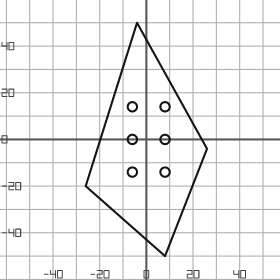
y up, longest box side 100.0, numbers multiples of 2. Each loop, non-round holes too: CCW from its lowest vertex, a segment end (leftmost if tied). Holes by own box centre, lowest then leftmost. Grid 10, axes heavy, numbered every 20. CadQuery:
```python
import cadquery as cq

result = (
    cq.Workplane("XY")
    .moveTo(8.0, -50.0)
    .lineTo(26.0, -4.0)
    .lineTo(-4.0, 50.0)
    .lineTo(-26.0, -20.0)
    .close()
    .moveTo(-6.0, -14.0)
    .circle(2.0)
    .moveTo(8.0, -14.0)
    .circle(2.0)
    .moveTo(-6.0, 0.0)
    .circle(2.0)
    .moveTo(8.0, 0.0)
    .circle(2.0)
    .moveTo(-6.0, 14.0)
    .circle(2.0)
    .moveTo(8.0, 14.0)
    .circle(2.0)
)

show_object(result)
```